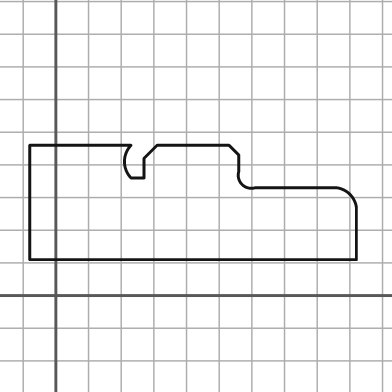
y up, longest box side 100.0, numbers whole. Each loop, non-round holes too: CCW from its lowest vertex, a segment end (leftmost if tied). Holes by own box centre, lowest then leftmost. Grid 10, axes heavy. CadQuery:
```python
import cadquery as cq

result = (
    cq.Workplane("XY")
    .moveTo(-8.0, 11.0)
    .lineTo(92.0, 11.0)
    .lineTo(92.0, 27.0)
    .threePointArc((90.0, 31.0), (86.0, 33.0))
    .lineTo(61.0, 33.0)
    .threePointArc((57.0, 34.0), (56.0, 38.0))
    .lineTo(56.0, 43.0)
    .lineTo(53.0, 46.0)
    .lineTo(31.0, 46.0)
    .lineTo(27.0, 42.0)
    .lineTo(27.0, 36.0)
    .lineTo(23.0, 36.0)
    .threePointArc((21.0, 41.0), (23.0, 46.0))
    .lineTo(-8.0, 46.0)
    .close()
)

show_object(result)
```